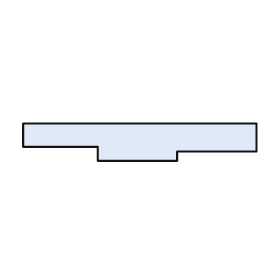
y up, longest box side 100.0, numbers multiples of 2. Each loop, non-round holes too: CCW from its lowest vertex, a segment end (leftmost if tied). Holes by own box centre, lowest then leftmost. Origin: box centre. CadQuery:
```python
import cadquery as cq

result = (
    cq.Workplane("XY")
    .moveTo(-18.0, -8.0)
    .lineTo(16.0, -8.0)
    .lineTo(16.0, -4.0)
    .lineTo(50.0, -4.0)
    .lineTo(50.0, 8.0)
    .lineTo(-50.0, 8.0)
    .lineTo(-50.0, -2.0)
    .lineTo(-18.0, -2.0)
    .close()
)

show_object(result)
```